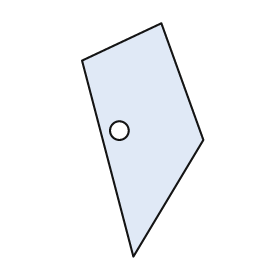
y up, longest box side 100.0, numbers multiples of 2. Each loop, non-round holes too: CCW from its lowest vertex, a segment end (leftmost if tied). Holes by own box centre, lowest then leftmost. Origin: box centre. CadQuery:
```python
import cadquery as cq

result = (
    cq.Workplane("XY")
    .moveTo(-4.0, -50.0)
    .lineTo(26.0, 0.0)
    .lineTo(8.0, 50.0)
    .lineTo(-26.0, 34.0)
    .close()
    .moveTo(-10.0, 4.0)
    .circle(4.0)
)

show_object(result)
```